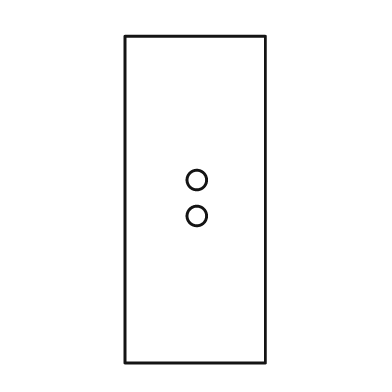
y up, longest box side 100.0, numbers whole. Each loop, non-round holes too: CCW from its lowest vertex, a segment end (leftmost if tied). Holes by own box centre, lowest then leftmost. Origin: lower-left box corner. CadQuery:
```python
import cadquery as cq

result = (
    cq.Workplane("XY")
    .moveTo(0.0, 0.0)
    .lineTo(43.0, 0.0)
    .lineTo(43.0, 100.0)
    .lineTo(0.0, 100.0)
    .close()
    .moveTo(22.0, 45.0)
    .circle(3.0)
    .moveTo(22.0, 56.0)
    .circle(3.0)
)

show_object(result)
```